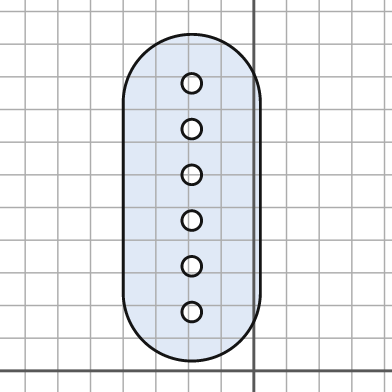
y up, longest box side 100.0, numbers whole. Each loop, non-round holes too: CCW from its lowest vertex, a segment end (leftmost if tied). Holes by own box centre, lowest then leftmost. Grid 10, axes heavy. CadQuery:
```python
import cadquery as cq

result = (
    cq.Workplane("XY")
    .moveTo(-40.0, 24.0)
    .threePointArc((-19.0, 3.0), (2.0, 24.0))
    .lineTo(2.0, 82.0)
    .threePointArc((-19.0, 103.0), (-40.0, 82.0))
    .close()
    .moveTo(-19.0, 18.0)
    .circle(3.0)
    .moveTo(-19.0, 32.0)
    .circle(3.0)
    .moveTo(-19.0, 46.0)
    .circle(3.0)
    .moveTo(-19.0, 60.0)
    .circle(3.0)
    .moveTo(-19.0, 74.0)
    .circle(3.0)
    .moveTo(-19.0, 88.0)
    .circle(3.0)
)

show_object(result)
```